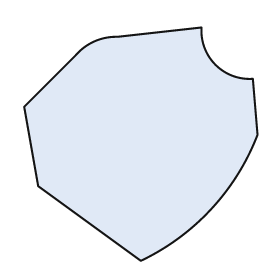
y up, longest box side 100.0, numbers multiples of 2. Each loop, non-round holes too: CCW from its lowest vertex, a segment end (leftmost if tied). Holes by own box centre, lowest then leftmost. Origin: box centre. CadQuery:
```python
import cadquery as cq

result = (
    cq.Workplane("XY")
    .moveTo(0.0, -50.0)
    .threePointArc((30.0, -28.0), (50.0, 4.0))
    .lineTo(48.0, 28.0)
    .threePointArc((32.0, 34.0), (26.0, 50.0))
    .lineTo(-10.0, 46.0)
    .threePointArc((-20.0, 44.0), (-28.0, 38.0))
    .lineTo(-50.0, 16.0)
    .lineTo(-44.0, -18.0)
    .close()
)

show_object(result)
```